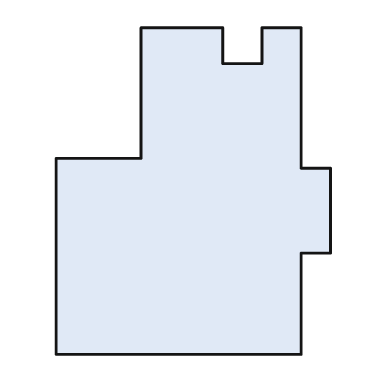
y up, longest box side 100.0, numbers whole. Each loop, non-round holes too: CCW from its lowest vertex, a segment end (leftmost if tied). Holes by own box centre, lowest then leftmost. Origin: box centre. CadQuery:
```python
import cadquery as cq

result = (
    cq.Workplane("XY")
    .moveTo(-42.0, -50.0)
    .lineTo(33.0, -50.0)
    .lineTo(33.0, -19.0)
    .lineTo(42.0, -19.0)
    .lineTo(42.0, 7.0)
    .lineTo(33.0, 7.0)
    .lineTo(33.0, 50.0)
    .lineTo(21.0, 50.0)
    .lineTo(21.0, 39.0)
    .lineTo(9.0, 39.0)
    .lineTo(9.0, 50.0)
    .lineTo(-16.0, 50.0)
    .lineTo(-16.0, 10.0)
    .lineTo(-42.0, 10.0)
    .close()
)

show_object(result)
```